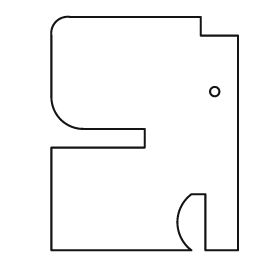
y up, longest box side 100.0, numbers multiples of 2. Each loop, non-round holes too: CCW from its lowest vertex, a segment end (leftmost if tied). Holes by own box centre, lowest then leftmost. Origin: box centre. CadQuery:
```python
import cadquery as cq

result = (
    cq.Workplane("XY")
    .moveTo(-40.0, -50.0)
    .lineTo(20.0, -50.0)
    .threePointArc((14.0, -38.0), (20.0, -26.0))
    .lineTo(26.0, -26.0)
    .lineTo(26.0, -50.0)
    .lineTo(40.0, -50.0)
    .lineTo(40.0, 42.0)
    .lineTo(24.0, 42.0)
    .lineTo(24.0, 50.0)
    .lineTo(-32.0, 50.0)
    .threePointArc((-38.0, 48.0), (-40.0, 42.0))
    .lineTo(-40.0, 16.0)
    .threePointArc((-36.0, 6.0), (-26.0, 2.0))
    .lineTo(0.0, 2.0)
    .lineTo(0.0, -6.0)
    .lineTo(-40.0, -6.0)
    .close()
    .moveTo(30.0, 18.0)
    .circle(2.0)
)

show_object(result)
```